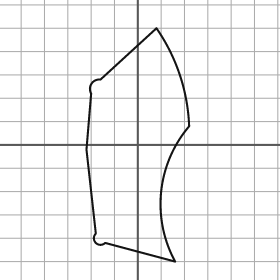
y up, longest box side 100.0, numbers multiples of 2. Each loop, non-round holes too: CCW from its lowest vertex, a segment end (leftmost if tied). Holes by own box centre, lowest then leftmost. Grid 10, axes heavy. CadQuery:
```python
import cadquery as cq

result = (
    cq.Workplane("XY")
    .moveTo(16.0, -50.0)
    .threePointArc((10.0, -20.0), (22.0, 8.0))
    .threePointArc((18.0, 30.0), (8.0, 50.0))
    .lineTo(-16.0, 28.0)
    .threePointArc((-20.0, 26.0), (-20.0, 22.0))
    .lineTo(-22.0, -2.0)
    .lineTo(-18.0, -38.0)
    .threePointArc((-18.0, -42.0), (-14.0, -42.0))
    .close()
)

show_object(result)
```